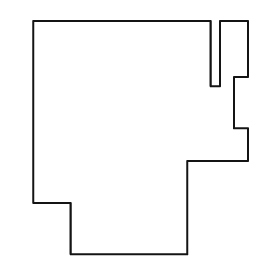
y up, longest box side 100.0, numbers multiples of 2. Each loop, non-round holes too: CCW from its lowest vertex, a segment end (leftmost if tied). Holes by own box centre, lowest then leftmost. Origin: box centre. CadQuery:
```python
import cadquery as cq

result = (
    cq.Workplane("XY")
    .moveTo(-30.0, -50.0)
    .lineTo(20.0, -50.0)
    .lineTo(20.0, -10.0)
    .lineTo(46.0, -10.0)
    .lineTo(46.0, 4.0)
    .lineTo(40.0, 4.0)
    .lineTo(40.0, 26.0)
    .lineTo(46.0, 26.0)
    .lineTo(46.0, 50.0)
    .lineTo(34.0, 50.0)
    .lineTo(34.0, 22.0)
    .lineTo(30.0, 22.0)
    .lineTo(30.0, 50.0)
    .lineTo(-46.0, 50.0)
    .lineTo(-46.0, -28.0)
    .lineTo(-30.0, -28.0)
    .close()
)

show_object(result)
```